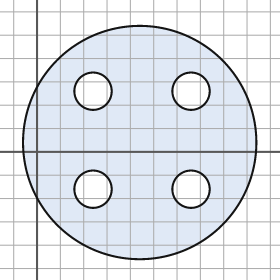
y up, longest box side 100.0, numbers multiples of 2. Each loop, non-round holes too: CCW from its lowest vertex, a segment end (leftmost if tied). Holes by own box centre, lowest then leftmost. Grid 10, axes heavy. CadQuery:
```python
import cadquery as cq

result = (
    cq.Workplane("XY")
    .moveTo(44.0, 4.0)
    .circle(50.0)
    .moveTo(24.0, -16.0)
    .circle(8.0)
    .moveTo(66.0, -16.0)
    .circle(8.0)
    .moveTo(24.0, 26.0)
    .circle(8.0)
    .moveTo(66.0, 26.0)
    .circle(8.0)
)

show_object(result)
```